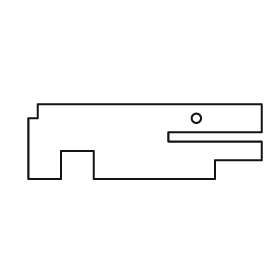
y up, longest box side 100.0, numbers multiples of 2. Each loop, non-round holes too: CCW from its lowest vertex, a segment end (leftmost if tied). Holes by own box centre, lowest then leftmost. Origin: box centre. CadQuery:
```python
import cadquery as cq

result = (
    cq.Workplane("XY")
    .moveTo(-50.0, -16.0)
    .lineTo(-36.0, -16.0)
    .lineTo(-36.0, -4.0)
    .lineTo(-22.0, -4.0)
    .lineTo(-22.0, -16.0)
    .lineTo(30.0, -16.0)
    .lineTo(30.0, -8.0)
    .lineTo(50.0, -8.0)
    .lineTo(50.0, 0.0)
    .lineTo(10.0, 0.0)
    .lineTo(10.0, 4.0)
    .lineTo(50.0, 4.0)
    .lineTo(50.0, 16.0)
    .lineTo(-46.0, 16.0)
    .lineTo(-46.0, 10.0)
    .lineTo(-50.0, 10.0)
    .close()
    .moveTo(22.0, 10.0)
    .circle(2.0)
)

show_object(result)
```